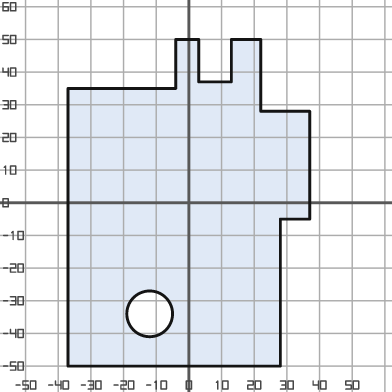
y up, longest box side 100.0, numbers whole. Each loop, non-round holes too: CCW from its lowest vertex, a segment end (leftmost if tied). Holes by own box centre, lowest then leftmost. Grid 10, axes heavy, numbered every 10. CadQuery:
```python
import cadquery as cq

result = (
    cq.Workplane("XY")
    .moveTo(-37.0, -50.0)
    .lineTo(28.0, -50.0)
    .lineTo(28.0, -5.0)
    .lineTo(37.0, -5.0)
    .lineTo(37.0, 28.0)
    .lineTo(22.0, 28.0)
    .lineTo(22.0, 50.0)
    .lineTo(13.0, 50.0)
    .lineTo(13.0, 37.0)
    .lineTo(3.0, 37.0)
    .lineTo(3.0, 50.0)
    .lineTo(-4.0, 50.0)
    .lineTo(-4.0, 35.0)
    .lineTo(-37.0, 35.0)
    .close()
    .moveTo(-12.0, -34.0)
    .circle(7.0)
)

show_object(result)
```